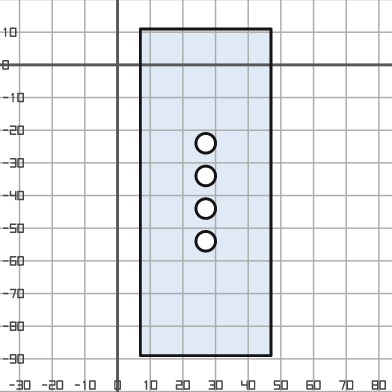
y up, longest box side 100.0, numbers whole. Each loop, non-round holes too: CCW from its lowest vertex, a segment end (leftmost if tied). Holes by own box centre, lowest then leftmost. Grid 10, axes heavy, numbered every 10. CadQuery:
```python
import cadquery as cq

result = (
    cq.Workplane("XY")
    .moveTo(7.0, -89.0)
    .lineTo(47.0, -89.0)
    .lineTo(47.0, 11.0)
    .lineTo(7.0, 11.0)
    .close()
    .moveTo(27.0, -54.0)
    .circle(3.0)
    .moveTo(27.0, -44.0)
    .circle(3.0)
    .moveTo(27.0, -34.0)
    .circle(3.0)
    .moveTo(27.0, -24.0)
    .circle(3.0)
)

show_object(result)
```